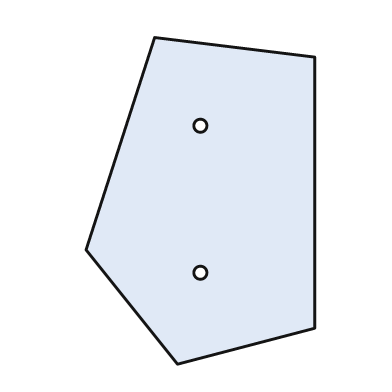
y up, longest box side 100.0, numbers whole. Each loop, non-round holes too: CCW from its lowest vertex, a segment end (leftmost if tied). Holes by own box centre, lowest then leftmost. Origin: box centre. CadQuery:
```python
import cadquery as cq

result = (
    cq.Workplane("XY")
    .moveTo(-7.0, -50.0)
    .lineTo(35.0, -39.0)
    .lineTo(35.0, 44.0)
    .lineTo(-14.0, 50.0)
    .lineTo(-35.0, -15.0)
    .close()
    .moveTo(0.0, -22.0)
    .circle(2.0)
    .moveTo(0.0, 23.0)
    .circle(2.0)
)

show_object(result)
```